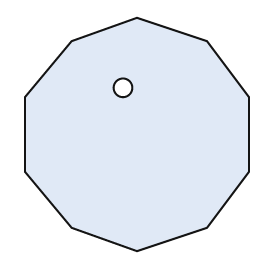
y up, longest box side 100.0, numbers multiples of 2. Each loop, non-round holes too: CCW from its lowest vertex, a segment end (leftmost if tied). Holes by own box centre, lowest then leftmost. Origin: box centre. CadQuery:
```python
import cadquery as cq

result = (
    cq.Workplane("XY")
    .moveTo(0.0, -50.0)
    .lineTo(30.0, -40.0)
    .lineTo(48.0, -16.0)
    .lineTo(48.0, 16.0)
    .lineTo(30.0, 40.0)
    .lineTo(0.0, 50.0)
    .lineTo(-28.0, 40.0)
    .lineTo(-48.0, 16.0)
    .lineTo(-48.0, -16.0)
    .lineTo(-28.0, -40.0)
    .close()
    .moveTo(-6.0, 20.0)
    .circle(4.0)
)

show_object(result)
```